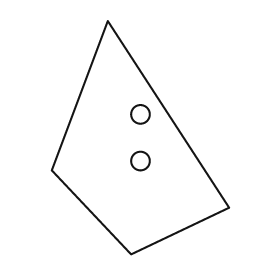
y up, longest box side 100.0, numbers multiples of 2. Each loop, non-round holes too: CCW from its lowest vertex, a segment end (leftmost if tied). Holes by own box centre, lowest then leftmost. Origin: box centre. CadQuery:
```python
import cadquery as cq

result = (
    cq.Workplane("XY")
    .moveTo(-4.0, -50.0)
    .lineTo(38.0, -30.0)
    .lineTo(-14.0, 50.0)
    .lineTo(-38.0, -14.0)
    .close()
    .moveTo(0.0, -10.0)
    .circle(4.0)
    .moveTo(0.0, 10.0)
    .circle(4.0)
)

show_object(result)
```